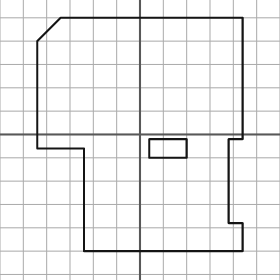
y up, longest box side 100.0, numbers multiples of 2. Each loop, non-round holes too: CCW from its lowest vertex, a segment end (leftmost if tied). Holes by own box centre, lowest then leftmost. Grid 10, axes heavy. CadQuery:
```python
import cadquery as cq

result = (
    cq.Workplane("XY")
    .moveTo(-24.0, -50.0)
    .lineTo(44.0, -50.0)
    .lineTo(44.0, -38.0)
    .lineTo(38.0, -38.0)
    .lineTo(38.0, -2.0)
    .lineTo(44.0, -2.0)
    .lineTo(44.0, 50.0)
    .lineTo(-34.0, 50.0)
    .lineTo(-44.0, 40.0)
    .lineTo(-44.0, -6.0)
    .lineTo(-24.0, -6.0)
    .close()
    .moveTo(4.0, -10.0)
    .lineTo(20.0, -10.0)
    .lineTo(20.0, -2.0)
    .lineTo(4.0, -2.0)
    .close()
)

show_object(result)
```